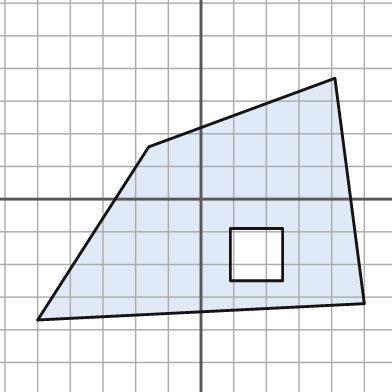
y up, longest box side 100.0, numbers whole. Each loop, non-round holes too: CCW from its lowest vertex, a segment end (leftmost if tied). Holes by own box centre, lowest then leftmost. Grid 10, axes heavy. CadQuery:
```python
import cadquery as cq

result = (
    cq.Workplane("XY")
    .moveTo(-50.0, -37.0)
    .lineTo(50.0, -32.0)
    .lineTo(41.0, 37.0)
    .lineTo(-16.0, 16.0)
    .close()
    .moveTo(9.0, -25.0)
    .lineTo(25.0, -25.0)
    .lineTo(25.0, -9.0)
    .lineTo(9.0, -9.0)
    .close()
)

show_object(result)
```